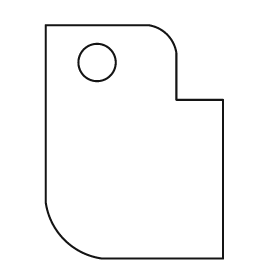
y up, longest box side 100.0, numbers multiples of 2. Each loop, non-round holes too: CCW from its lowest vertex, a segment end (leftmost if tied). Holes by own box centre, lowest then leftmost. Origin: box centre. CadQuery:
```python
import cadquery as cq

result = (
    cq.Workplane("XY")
    .moveTo(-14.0, -50.0)
    .lineTo(38.0, -50.0)
    .lineTo(38.0, 18.0)
    .lineTo(18.0, 18.0)
    .lineTo(18.0, 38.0)
    .threePointArc((14.0, 46.0), (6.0, 50.0))
    .lineTo(-38.0, 50.0)
    .lineTo(-38.0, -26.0)
    .threePointArc((-30.0, -42.0), (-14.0, -50.0))
    .close()
    .moveTo(-16.0, 34.0)
    .circle(8.0)
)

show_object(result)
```